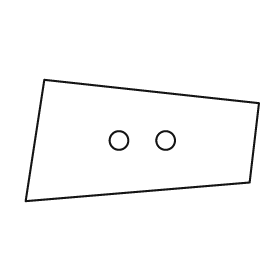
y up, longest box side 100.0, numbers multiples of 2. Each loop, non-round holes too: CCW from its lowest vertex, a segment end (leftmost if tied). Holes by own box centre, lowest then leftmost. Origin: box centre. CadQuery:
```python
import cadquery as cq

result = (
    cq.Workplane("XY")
    .moveTo(-50.0, -26.0)
    .lineTo(46.0, -18.0)
    .lineTo(50.0, 16.0)
    .lineTo(-42.0, 26.0)
    .close()
    .moveTo(-10.0, 0.0)
    .circle(4.0)
    .moveTo(10.0, 0.0)
    .circle(4.0)
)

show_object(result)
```